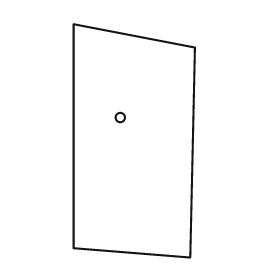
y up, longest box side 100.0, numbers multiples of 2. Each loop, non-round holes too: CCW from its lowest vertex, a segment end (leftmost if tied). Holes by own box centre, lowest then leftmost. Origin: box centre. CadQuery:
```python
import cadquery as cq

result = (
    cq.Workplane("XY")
    .moveTo(24.0, -50.0)
    .lineTo(26.0, 40.0)
    .lineTo(-26.0, 50.0)
    .lineTo(-26.0, -46.0)
    .close()
    .moveTo(-6.0, 10.0)
    .circle(2.0)
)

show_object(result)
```